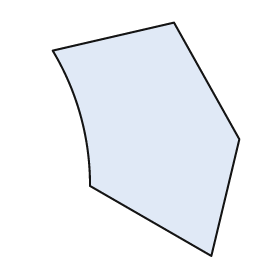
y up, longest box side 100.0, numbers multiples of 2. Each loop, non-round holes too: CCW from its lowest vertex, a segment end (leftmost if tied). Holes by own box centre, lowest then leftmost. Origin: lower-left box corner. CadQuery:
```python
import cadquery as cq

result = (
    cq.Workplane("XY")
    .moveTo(68.0, 0.0)
    .lineTo(80.0, 50.0)
    .lineTo(52.0, 100.0)
    .lineTo(0.0, 88.0)
    .threePointArc((12.0, 60.0), (16.0, 30.0))
    .close()
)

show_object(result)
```